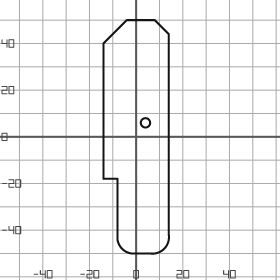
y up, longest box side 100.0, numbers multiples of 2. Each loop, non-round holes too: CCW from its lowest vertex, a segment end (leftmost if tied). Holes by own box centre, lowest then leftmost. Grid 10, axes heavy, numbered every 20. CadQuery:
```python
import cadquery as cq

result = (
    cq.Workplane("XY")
    .moveTo(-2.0, -50.0)
    .lineTo(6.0, -50.0)
    .threePointArc((12.0, -48.0), (14.0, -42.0))
    .lineTo(14.0, 44.0)
    .lineTo(8.0, 50.0)
    .lineTo(-4.0, 50.0)
    .lineTo(-14.0, 40.0)
    .lineTo(-14.0, -18.0)
    .lineTo(-8.0, -18.0)
    .lineTo(-8.0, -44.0)
    .threePointArc((-6.0, -48.0), (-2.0, -50.0))
    .close()
    .moveTo(4.0, 6.0)
    .circle(2.0)
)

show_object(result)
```